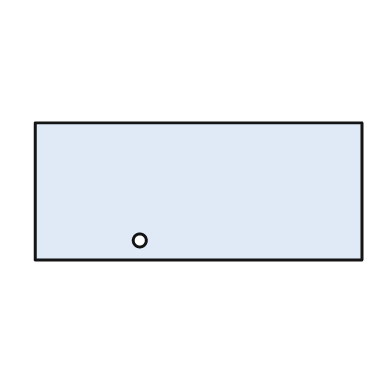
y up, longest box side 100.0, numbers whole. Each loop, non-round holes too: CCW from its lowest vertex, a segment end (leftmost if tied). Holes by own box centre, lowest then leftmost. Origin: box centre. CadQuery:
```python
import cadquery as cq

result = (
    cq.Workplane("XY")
    .moveTo(-50.0, -21.0)
    .lineTo(50.0, -21.0)
    .lineTo(50.0, 21.0)
    .lineTo(-50.0, 21.0)
    .close()
    .moveTo(-18.0, -15.0)
    .circle(2.0)
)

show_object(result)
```